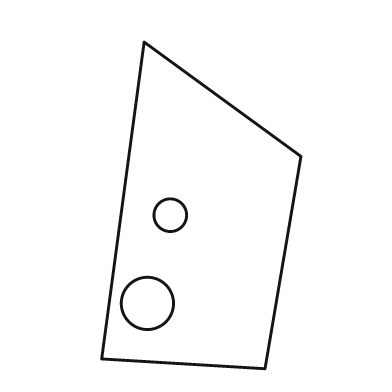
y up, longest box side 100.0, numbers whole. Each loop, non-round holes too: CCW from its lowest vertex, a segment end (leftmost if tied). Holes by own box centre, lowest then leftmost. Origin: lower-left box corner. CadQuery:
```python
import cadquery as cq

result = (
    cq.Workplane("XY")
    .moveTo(50.0, 0.0)
    .lineTo(61.0, 65.0)
    .lineTo(13.0, 100.0)
    .lineTo(0.0, 3.0)
    .close()
    .moveTo(14.0, 20.0)
    .circle(8.0)
    .moveTo(21.0, 47.0)
    .circle(5.0)
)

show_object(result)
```